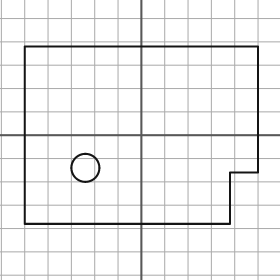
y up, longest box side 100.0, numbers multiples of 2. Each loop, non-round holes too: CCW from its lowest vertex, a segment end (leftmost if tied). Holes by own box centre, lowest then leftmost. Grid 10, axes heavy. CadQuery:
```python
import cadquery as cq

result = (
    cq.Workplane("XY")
    .moveTo(-50.0, -38.0)
    .lineTo(38.0, -38.0)
    .lineTo(38.0, -16.0)
    .lineTo(50.0, -16.0)
    .lineTo(50.0, 38.0)
    .lineTo(-50.0, 38.0)
    .close()
    .moveTo(-24.0, -14.0)
    .circle(6.0)
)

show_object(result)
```